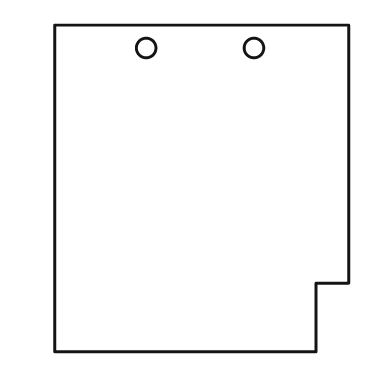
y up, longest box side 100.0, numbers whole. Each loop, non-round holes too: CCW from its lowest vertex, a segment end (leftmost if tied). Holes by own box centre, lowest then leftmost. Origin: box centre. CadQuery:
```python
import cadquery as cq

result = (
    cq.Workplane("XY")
    .moveTo(-45.0, -50.0)
    .lineTo(35.0, -50.0)
    .lineTo(35.0, -29.0)
    .lineTo(45.0, -29.0)
    .lineTo(45.0, 50.0)
    .lineTo(-45.0, 50.0)
    .close()
    .moveTo(-17.0, 43.0)
    .circle(3.0)
    .moveTo(16.0, 43.0)
    .circle(3.0)
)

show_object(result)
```